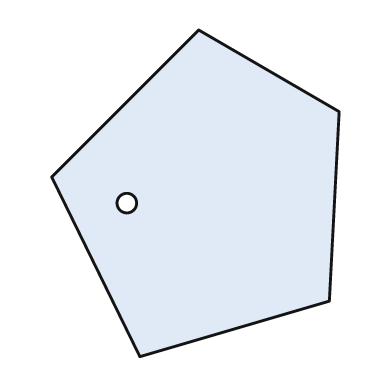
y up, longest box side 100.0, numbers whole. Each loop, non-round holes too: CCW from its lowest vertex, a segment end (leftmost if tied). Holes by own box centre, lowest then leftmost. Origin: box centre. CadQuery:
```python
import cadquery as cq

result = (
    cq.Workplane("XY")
    .moveTo(-17.0, -50.0)
    .lineTo(41.0, -33.0)
    .lineTo(44.0, 25.0)
    .lineTo(1.0, 50.0)
    .lineTo(-44.0, 5.0)
    .close()
    .moveTo(-21.0, -3.0)
    .circle(3.0)
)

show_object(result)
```